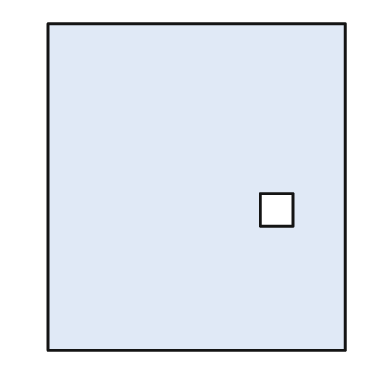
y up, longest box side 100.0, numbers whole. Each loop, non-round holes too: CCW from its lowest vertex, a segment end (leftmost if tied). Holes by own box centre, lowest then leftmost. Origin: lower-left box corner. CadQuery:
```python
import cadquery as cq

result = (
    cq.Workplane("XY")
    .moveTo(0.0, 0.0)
    .lineTo(91.0, 0.0)
    .lineTo(91.0, 100.0)
    .lineTo(0.0, 100.0)
    .close()
    .moveTo(65.0, 38.0)
    .lineTo(75.0, 38.0)
    .lineTo(75.0, 48.0)
    .lineTo(65.0, 48.0)
    .close()
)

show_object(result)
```